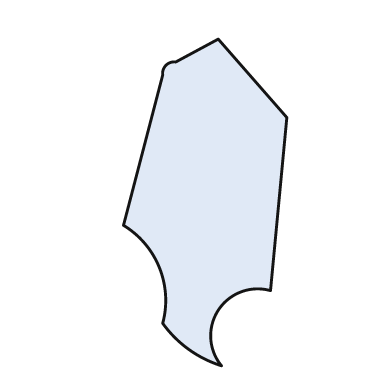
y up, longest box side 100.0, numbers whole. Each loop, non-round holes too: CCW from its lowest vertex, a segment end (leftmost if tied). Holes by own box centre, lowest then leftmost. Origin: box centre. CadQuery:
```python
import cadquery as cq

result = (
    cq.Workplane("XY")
    .moveTo(5.0, -50.0)
    .threePointArc((4.0, -33.0), (20.0, -27.0))
    .lineTo(25.0, 26.0)
    .lineTo(4.0, 50.0)
    .lineTo(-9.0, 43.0)
    .threePointArc((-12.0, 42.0), (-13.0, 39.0))
    .lineTo(-25.0, -7.0)
    .threePointArc((-14.0, -20.0), (-13.0, -37.0))
    .threePointArc((-5.0, -45.0), (5.0, -50.0))
    .close()
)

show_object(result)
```